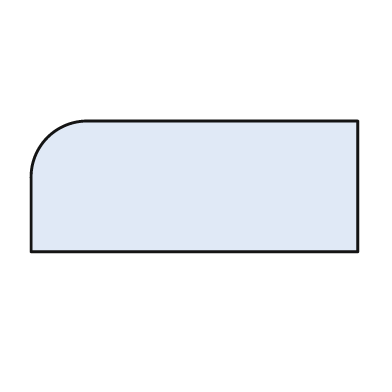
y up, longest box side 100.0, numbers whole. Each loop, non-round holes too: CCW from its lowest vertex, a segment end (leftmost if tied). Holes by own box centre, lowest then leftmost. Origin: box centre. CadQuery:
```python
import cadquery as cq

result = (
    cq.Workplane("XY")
    .moveTo(-50.0, -20.0)
    .lineTo(50.0, -20.0)
    .lineTo(50.0, 20.0)
    .lineTo(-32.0, 20.0)
    .threePointArc((-45.0, 15.0), (-50.0, 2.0))
    .close()
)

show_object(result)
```